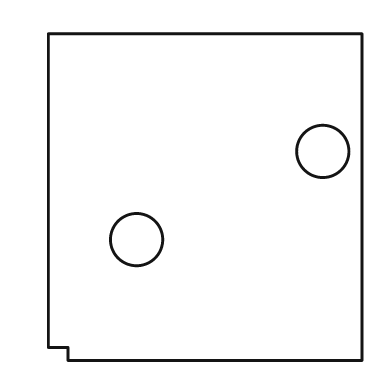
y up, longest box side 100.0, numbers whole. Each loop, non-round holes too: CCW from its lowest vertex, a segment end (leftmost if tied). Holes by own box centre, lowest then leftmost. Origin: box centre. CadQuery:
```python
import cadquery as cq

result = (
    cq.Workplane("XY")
    .moveTo(-42.0, -50.0)
    .lineTo(48.0, -50.0)
    .lineTo(48.0, 50.0)
    .lineTo(-48.0, 50.0)
    .lineTo(-48.0, -46.0)
    .lineTo(-42.0, -46.0)
    .close()
    .moveTo(-21.0, -13.0)
    .circle(8.0)
    .moveTo(36.0, 14.0)
    .circle(8.0)
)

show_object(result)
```